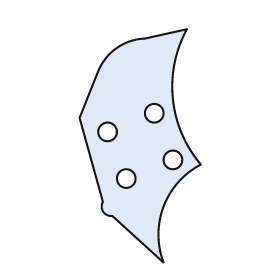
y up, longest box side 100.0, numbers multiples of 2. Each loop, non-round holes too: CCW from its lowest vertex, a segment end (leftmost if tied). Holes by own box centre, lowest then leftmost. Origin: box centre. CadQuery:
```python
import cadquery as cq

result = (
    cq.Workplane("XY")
    .moveTo(10.0, -50.0)
    .threePointArc((10.0, -26.0), (26.0, -8.0))
    .threePointArc((14.0, 20.0), (20.0, 50.0))
    .lineTo(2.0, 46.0)
    .threePointArc((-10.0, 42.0), (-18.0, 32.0))
    .lineTo(-26.0, 12.0)
    .lineTo(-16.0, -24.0)
    .threePointArc((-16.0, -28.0), (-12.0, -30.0))
    .close()
    .moveTo(-6.0, -14.0)
    .circle(4.0)
    .moveTo(14.0, -6.0)
    .circle(4.0)
    .moveTo(-14.0, 6.0)
    .circle(4.0)
    .moveTo(6.0, 14.0)
    .circle(4.0)
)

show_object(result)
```